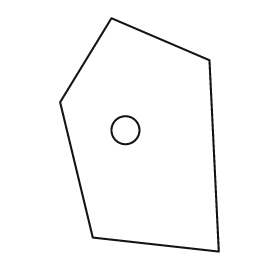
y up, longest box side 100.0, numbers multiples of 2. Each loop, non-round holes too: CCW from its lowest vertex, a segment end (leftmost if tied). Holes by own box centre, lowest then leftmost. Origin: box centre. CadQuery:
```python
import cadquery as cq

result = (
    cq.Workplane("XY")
    .moveTo(34.0, -50.0)
    .lineTo(30.0, 32.0)
    .lineTo(-12.0, 50.0)
    .lineTo(-34.0, 14.0)
    .lineTo(-20.0, -44.0)
    .close()
    .moveTo(-6.0, 2.0)
    .circle(6.0)
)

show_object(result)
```